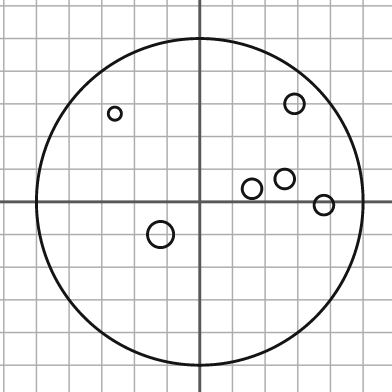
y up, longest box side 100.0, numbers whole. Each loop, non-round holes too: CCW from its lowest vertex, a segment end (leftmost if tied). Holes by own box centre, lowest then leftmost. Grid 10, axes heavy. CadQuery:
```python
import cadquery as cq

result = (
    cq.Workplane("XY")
    .moveTo(0.0, 0.0)
    .circle(50.0)
    .moveTo(-12.0, -10.0)
    .circle(4.0)
    .moveTo(38.0, -1.0)
    .circle(3.0)
    .moveTo(16.0, 4.0)
    .circle(3.0)
    .moveTo(26.0, 7.0)
    .circle(3.0)
    .moveTo(-26.0, 27.0)
    .circle(2.0)
    .moveTo(29.0, 30.0)
    .circle(3.0)
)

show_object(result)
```